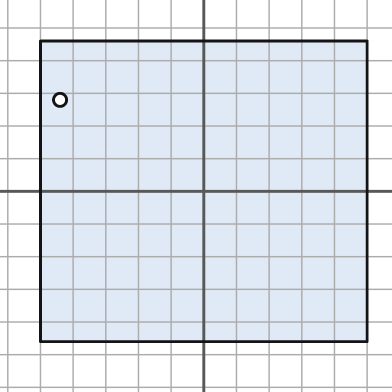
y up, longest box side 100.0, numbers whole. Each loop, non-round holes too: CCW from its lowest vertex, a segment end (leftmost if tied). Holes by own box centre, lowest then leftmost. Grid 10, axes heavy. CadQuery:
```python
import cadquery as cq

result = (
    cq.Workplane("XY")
    .moveTo(-50.0, -46.0)
    .lineTo(50.0, -46.0)
    .lineTo(50.0, 46.0)
    .lineTo(-50.0, 46.0)
    .close()
    .moveTo(-44.0, 28.0)
    .circle(2.0)
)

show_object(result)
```